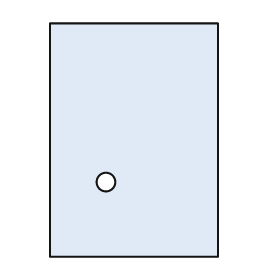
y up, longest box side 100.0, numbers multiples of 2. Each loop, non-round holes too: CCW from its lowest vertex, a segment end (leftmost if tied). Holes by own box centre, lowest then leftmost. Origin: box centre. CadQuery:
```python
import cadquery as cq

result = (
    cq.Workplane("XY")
    .moveTo(-36.0, -50.0)
    .lineTo(36.0, -50.0)
    .lineTo(36.0, 50.0)
    .lineTo(-36.0, 50.0)
    .close()
    .moveTo(-12.0, -18.0)
    .circle(4.0)
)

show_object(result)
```